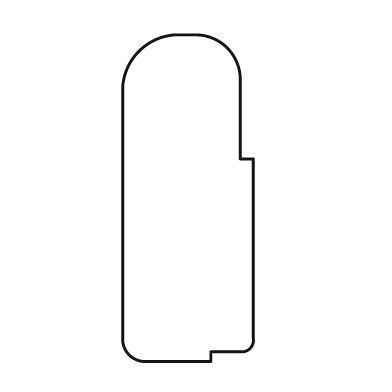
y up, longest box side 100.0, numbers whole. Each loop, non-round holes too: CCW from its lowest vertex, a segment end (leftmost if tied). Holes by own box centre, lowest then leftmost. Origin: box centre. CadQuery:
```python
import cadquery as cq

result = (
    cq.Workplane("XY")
    .moveTo(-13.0, -50.0)
    .lineTo(7.0, -50.0)
    .lineTo(7.0, -47.0)
    .lineTo(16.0, -47.0)
    .threePointArc((19.0, -46.0), (20.0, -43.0))
    .lineTo(20.0, 12.0)
    .lineTo(16.0, 12.0)
    .lineTo(16.0, 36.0)
    .threePointArc((12.0, 46.0), (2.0, 50.0))
    .lineTo(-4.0, 50.0)
    .threePointArc((-15.0, 45.0), (-20.0, 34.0))
    .lineTo(-20.0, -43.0)
    .threePointArc((-18.0, -48.0), (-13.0, -50.0))
    .close()
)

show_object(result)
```